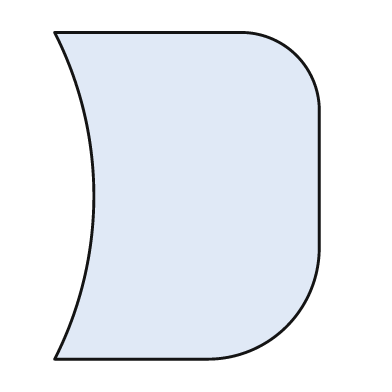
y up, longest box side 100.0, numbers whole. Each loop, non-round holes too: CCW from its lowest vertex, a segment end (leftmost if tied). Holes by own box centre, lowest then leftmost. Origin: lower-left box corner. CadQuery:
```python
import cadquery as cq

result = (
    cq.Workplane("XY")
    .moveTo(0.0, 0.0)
    .lineTo(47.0, 0.0)
    .threePointArc((71.0, 10.0), (81.0, 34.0))
    .lineTo(81.0, 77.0)
    .threePointArc((74.0, 93.0), (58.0, 100.0))
    .lineTo(0.0, 100.0)
    .threePointArc((12.0, 50.0), (0.0, 0.0))
    .close()
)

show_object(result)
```